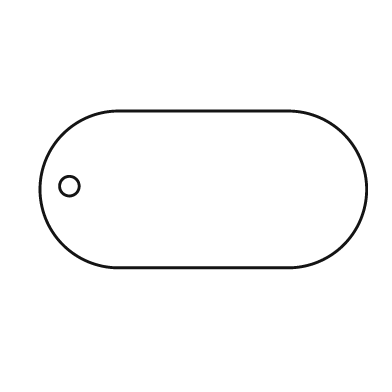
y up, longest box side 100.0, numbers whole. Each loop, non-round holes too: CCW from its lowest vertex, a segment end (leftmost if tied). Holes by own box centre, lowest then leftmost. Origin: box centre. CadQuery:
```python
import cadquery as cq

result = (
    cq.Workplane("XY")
    .moveTo(-26.0, -24.0)
    .lineTo(26.0, -24.0)
    .threePointArc((50.0, 0.0), (26.0, 24.0))
    .lineTo(-26.0, 24.0)
    .threePointArc((-50.0, 0.0), (-26.0, -24.0))
    .close()
    .moveTo(-41.0, 1.0)
    .circle(3.0)
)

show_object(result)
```